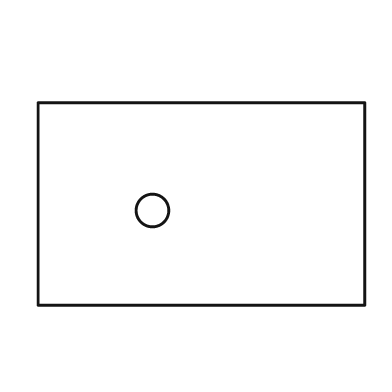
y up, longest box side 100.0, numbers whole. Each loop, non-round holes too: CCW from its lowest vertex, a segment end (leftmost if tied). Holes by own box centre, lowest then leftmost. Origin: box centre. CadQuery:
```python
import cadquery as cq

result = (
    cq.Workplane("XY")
    .moveTo(-50.0, -31.0)
    .lineTo(50.0, -31.0)
    .lineTo(50.0, 31.0)
    .lineTo(-50.0, 31.0)
    .close()
    .moveTo(-15.0, -2.0)
    .circle(5.0)
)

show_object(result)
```